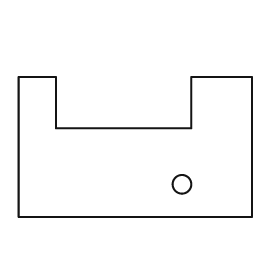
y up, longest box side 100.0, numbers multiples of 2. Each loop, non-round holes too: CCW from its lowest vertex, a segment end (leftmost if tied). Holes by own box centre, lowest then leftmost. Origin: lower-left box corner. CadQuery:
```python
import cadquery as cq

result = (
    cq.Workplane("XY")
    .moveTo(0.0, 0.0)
    .lineTo(100.0, 0.0)
    .lineTo(100.0, 60.0)
    .lineTo(74.0, 60.0)
    .lineTo(74.0, 38.0)
    .lineTo(16.0, 38.0)
    .lineTo(16.0, 60.0)
    .lineTo(0.0, 60.0)
    .close()
    .moveTo(70.0, 14.0)
    .circle(4.0)
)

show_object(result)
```